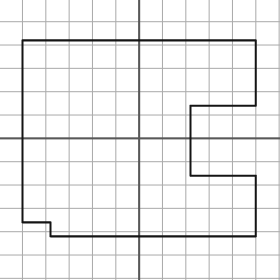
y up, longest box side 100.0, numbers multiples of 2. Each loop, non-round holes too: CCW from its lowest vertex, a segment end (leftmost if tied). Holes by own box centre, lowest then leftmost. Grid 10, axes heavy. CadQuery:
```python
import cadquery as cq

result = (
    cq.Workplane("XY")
    .moveTo(-38.0, -42.0)
    .lineTo(50.0, -42.0)
    .lineTo(50.0, -16.0)
    .lineTo(22.0, -16.0)
    .lineTo(22.0, 14.0)
    .lineTo(50.0, 14.0)
    .lineTo(50.0, 42.0)
    .lineTo(-50.0, 42.0)
    .lineTo(-50.0, -36.0)
    .lineTo(-38.0, -36.0)
    .close()
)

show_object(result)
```